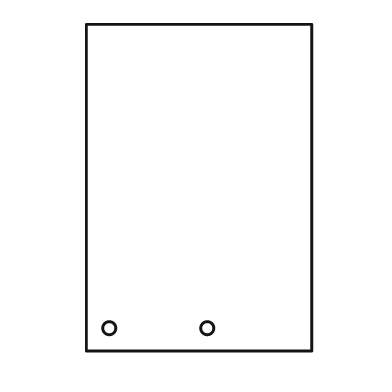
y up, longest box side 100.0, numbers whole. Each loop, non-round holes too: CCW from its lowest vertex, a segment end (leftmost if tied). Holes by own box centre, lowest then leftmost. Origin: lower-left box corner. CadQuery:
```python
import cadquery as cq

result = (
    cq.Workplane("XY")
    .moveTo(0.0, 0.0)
    .lineTo(69.0, 0.0)
    .lineTo(69.0, 100.0)
    .lineTo(0.0, 100.0)
    .close()
    .moveTo(7.0, 7.0)
    .circle(2.0)
    .moveTo(37.0, 7.0)
    .circle(2.0)
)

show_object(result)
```